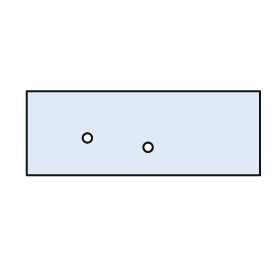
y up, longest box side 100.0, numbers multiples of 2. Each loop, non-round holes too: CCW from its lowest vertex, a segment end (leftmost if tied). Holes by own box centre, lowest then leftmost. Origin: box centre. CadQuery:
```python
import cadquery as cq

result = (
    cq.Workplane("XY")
    .moveTo(-50.0, -18.0)
    .lineTo(50.0, -18.0)
    .lineTo(50.0, 18.0)
    .lineTo(-50.0, 18.0)
    .close()
    .moveTo(2.0, -6.0)
    .circle(2.0)
    .moveTo(-24.0, -2.0)
    .circle(2.0)
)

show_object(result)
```